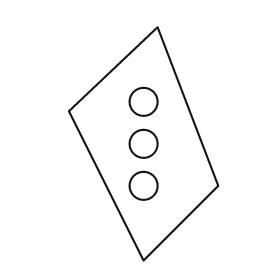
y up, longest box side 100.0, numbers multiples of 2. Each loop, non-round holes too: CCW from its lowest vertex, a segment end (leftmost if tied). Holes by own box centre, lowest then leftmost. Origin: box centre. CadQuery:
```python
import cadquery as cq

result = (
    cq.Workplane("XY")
    .moveTo(0.0, -50.0)
    .lineTo(32.0, -18.0)
    .lineTo(6.0, 50.0)
    .lineTo(-32.0, 14.0)
    .close()
    .moveTo(0.0, -18.0)
    .circle(6.0)
    .moveTo(0.0, 0.0)
    .circle(6.0)
    .moveTo(0.0, 18.0)
    .circle(6.0)
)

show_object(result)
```